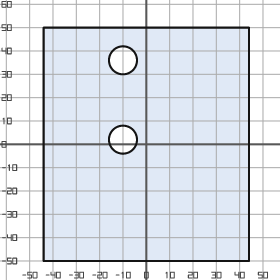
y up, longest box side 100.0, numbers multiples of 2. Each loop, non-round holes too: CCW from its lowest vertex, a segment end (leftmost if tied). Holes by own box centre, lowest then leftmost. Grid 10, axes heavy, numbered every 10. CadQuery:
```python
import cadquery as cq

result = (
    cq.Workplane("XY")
    .moveTo(-44.0, -50.0)
    .lineTo(44.0, -50.0)
    .lineTo(44.0, 50.0)
    .lineTo(-44.0, 50.0)
    .close()
    .moveTo(-10.0, 2.0)
    .circle(6.0)
    .moveTo(-10.0, 36.0)
    .circle(6.0)
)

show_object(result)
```